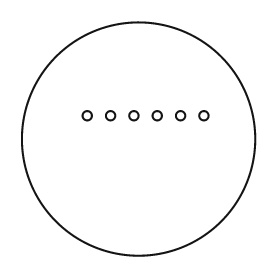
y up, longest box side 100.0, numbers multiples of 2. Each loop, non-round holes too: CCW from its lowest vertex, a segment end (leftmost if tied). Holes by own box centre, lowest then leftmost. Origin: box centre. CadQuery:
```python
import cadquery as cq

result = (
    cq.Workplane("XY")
    .moveTo(0.0, 0.0)
    .circle(50.0)
    .moveTo(-22.0, 10.0)
    .circle(2.0)
    .moveTo(-12.0, 10.0)
    .circle(2.0)
    .moveTo(-2.0, 10.0)
    .circle(2.0)
    .moveTo(8.0, 10.0)
    .circle(2.0)
    .moveTo(18.0, 10.0)
    .circle(2.0)
    .moveTo(28.0, 10.0)
    .circle(2.0)
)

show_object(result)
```